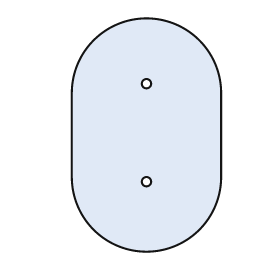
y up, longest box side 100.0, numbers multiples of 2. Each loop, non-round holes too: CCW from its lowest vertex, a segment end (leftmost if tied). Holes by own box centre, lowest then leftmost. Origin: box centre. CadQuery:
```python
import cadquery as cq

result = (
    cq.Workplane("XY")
    .moveTo(-32.0, -18.0)
    .threePointArc((0.0, -50.0), (32.0, -18.0))
    .lineTo(32.0, 18.0)
    .threePointArc((0.0, 50.0), (-32.0, 18.0))
    .close()
    .moveTo(0.0, -20.0)
    .circle(2.0)
    .moveTo(0.0, 22.0)
    .circle(2.0)
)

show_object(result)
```